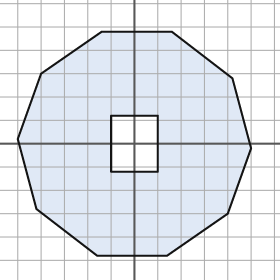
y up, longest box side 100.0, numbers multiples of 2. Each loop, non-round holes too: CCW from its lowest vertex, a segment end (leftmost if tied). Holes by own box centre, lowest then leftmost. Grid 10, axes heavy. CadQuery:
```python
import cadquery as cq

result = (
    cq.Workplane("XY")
    .moveTo(-16.0, -48.0)
    .lineTo(14.0, -48.0)
    .lineTo(40.0, -30.0)
    .lineTo(50.0, -2.0)
    .lineTo(42.0, 28.0)
    .lineTo(16.0, 48.0)
    .lineTo(-14.0, 48.0)
    .lineTo(-40.0, 30.0)
    .lineTo(-50.0, 2.0)
    .lineTo(-42.0, -28.0)
    .close()
    .moveTo(-10.0, -12.0)
    .lineTo(10.0, -12.0)
    .lineTo(10.0, 12.0)
    .lineTo(-10.0, 12.0)
    .close()
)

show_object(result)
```